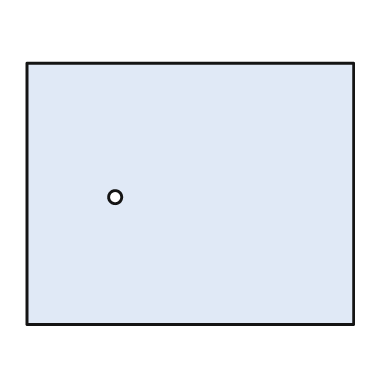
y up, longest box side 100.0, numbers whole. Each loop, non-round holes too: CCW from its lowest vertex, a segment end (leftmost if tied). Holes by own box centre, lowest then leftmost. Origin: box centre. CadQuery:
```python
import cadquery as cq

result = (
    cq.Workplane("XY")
    .moveTo(-50.0, -40.0)
    .lineTo(50.0, -40.0)
    .lineTo(50.0, 40.0)
    .lineTo(-50.0, 40.0)
    .close()
    .moveTo(-23.0, -1.0)
    .circle(2.0)
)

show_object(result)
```